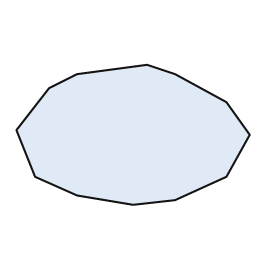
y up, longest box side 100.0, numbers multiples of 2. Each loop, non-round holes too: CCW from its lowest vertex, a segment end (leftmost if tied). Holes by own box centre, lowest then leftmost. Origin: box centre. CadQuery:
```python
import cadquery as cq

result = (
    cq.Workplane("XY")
    .moveTo(0.0, -30.0)
    .lineTo(18.0, -28.0)
    .lineTo(40.0, -18.0)
    .lineTo(50.0, 0.0)
    .lineTo(40.0, 14.0)
    .lineTo(18.0, 26.0)
    .lineTo(6.0, 30.0)
    .lineTo(-24.0, 26.0)
    .lineTo(-36.0, 20.0)
    .lineTo(-50.0, 2.0)
    .lineTo(-42.0, -18.0)
    .lineTo(-24.0, -26.0)
    .close()
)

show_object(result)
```